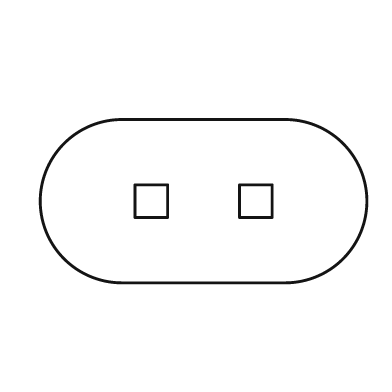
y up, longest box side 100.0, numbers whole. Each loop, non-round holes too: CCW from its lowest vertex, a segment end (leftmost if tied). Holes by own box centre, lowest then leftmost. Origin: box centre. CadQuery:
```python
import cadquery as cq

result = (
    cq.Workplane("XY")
    .moveTo(-25.0, -25.0)
    .lineTo(25.0, -25.0)
    .threePointArc((50.0, 0.0), (25.0, 25.0))
    .lineTo(-25.0, 25.0)
    .threePointArc((-50.0, 0.0), (-25.0, -25.0))
    .close()
    .moveTo(-21.0, -5.0)
    .lineTo(-11.0, -5.0)
    .lineTo(-11.0, 5.0)
    .lineTo(-21.0, 5.0)
    .close()
    .moveTo(11.0, -5.0)
    .lineTo(21.0, -5.0)
    .lineTo(21.0, 5.0)
    .lineTo(11.0, 5.0)
    .close()
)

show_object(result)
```